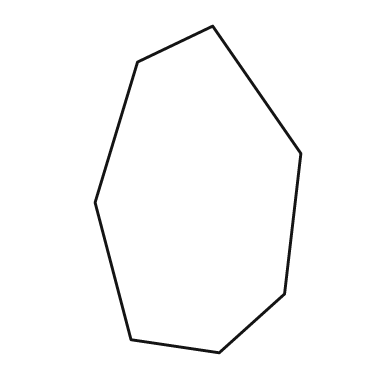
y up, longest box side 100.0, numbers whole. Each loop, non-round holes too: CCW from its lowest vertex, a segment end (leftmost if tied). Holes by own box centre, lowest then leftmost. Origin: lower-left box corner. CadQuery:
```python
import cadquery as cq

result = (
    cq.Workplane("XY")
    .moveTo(38.0, 0.0)
    .lineTo(58.0, 18.0)
    .lineTo(63.0, 61.0)
    .lineTo(36.0, 100.0)
    .lineTo(13.0, 89.0)
    .lineTo(0.0, 46.0)
    .lineTo(11.0, 4.0)
    .close()
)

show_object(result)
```